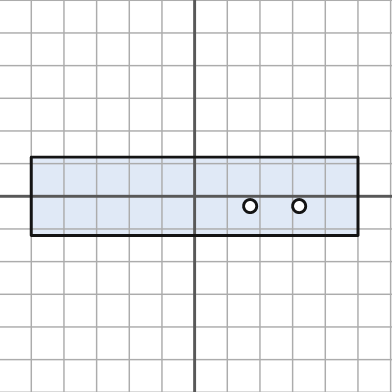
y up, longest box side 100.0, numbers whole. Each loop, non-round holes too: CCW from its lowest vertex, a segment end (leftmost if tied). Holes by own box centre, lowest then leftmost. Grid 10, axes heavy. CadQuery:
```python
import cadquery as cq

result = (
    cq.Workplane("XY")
    .moveTo(-50.0, -12.0)
    .lineTo(50.0, -12.0)
    .lineTo(50.0, 12.0)
    .lineTo(-50.0, 12.0)
    .close()
    .moveTo(17.0, -3.0)
    .circle(2.0)
    .moveTo(32.0, -3.0)
    .circle(2.0)
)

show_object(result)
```